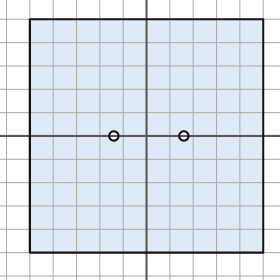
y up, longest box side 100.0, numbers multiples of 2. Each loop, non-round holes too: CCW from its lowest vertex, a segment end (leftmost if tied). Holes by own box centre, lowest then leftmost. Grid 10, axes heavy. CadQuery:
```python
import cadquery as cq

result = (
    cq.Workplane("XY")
    .moveTo(-50.0, -50.0)
    .lineTo(50.0, -50.0)
    .lineTo(50.0, 50.0)
    .lineTo(-50.0, 50.0)
    .close()
    .moveTo(-14.0, 0.0)
    .circle(2.0)
    .moveTo(16.0, 0.0)
    .circle(2.0)
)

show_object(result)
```